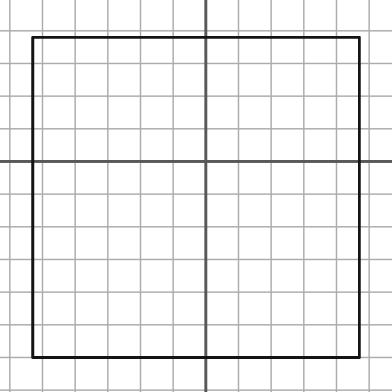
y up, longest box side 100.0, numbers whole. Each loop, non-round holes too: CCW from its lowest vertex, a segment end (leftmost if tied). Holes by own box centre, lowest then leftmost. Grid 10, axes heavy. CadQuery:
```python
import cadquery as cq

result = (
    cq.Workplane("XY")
    .moveTo(-53.0, -60.0)
    .lineTo(47.0, -60.0)
    .lineTo(47.0, 38.0)
    .lineTo(-53.0, 38.0)
    .close()
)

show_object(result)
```